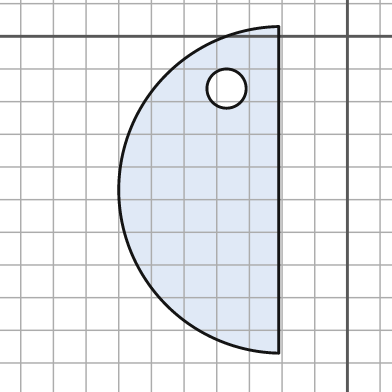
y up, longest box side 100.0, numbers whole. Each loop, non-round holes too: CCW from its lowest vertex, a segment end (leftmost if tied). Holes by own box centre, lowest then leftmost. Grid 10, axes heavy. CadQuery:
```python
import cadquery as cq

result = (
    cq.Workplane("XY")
    .moveTo(-21.0, -97.0)
    .lineTo(-21.0, 3.0)
    .threePointArc((-70.0, -47.0), (-21.0, -97.0))
    .close()
    .moveTo(-37.0, -16.0)
    .circle(6.0)
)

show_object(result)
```